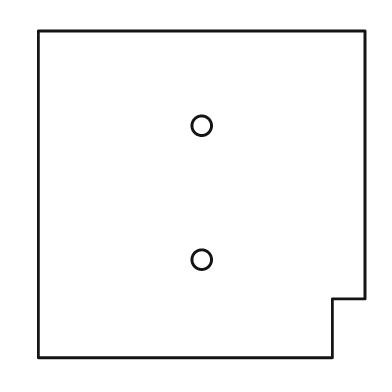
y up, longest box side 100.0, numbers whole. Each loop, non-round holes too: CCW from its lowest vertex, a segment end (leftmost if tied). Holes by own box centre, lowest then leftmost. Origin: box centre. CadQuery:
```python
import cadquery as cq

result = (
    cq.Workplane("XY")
    .moveTo(-50.0, -50.0)
    .lineTo(40.0, -50.0)
    .lineTo(40.0, -32.0)
    .lineTo(50.0, -32.0)
    .lineTo(50.0, 50.0)
    .lineTo(-50.0, 50.0)
    .close()
    .moveTo(0.0, -20.0)
    .circle(3.0)
    .moveTo(0.0, 21.0)
    .circle(3.0)
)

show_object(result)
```